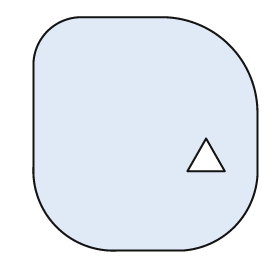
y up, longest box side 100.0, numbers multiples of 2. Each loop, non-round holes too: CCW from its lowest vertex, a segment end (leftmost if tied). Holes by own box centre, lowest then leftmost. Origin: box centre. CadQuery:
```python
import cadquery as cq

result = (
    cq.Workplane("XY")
    .moveTo(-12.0, -50.0)
    .lineTo(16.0, -50.0)
    .threePointArc((38.0, -40.0), (48.0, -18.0))
    .lineTo(48.0, 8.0)
    .threePointArc((36.0, 38.0), (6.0, 50.0))
    .lineTo(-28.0, 50.0)
    .threePointArc((-42.0, 44.0), (-48.0, 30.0))
    .lineTo(-48.0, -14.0)
    .threePointArc((-38.0, -40.0), (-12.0, -50.0))
    .close()
    .moveTo(18.0, -16.0)
    .lineTo(34.0, -16.0)
    .lineTo(26.0, -2.0)
    .close()
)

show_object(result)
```